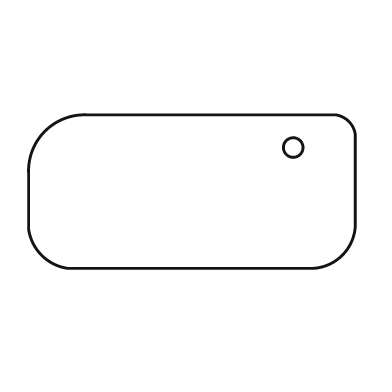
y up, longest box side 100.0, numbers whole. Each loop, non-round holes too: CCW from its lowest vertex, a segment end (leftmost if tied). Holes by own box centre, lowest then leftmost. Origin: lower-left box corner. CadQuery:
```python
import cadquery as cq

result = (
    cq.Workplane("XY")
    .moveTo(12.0, 0.0)
    .lineTo(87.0, 0.0)
    .threePointArc((96.0, 4.0), (100.0, 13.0))
    .lineTo(100.0, 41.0)
    .threePointArc((98.0, 45.0), (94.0, 47.0))
    .lineTo(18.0, 47.0)
    .threePointArc((5.0, 42.0), (0.0, 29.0))
    .lineTo(0.0, 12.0)
    .threePointArc((4.0, 4.0), (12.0, 0.0))
    .close()
    .moveTo(81.0, 37.0)
    .circle(3.0)
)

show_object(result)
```